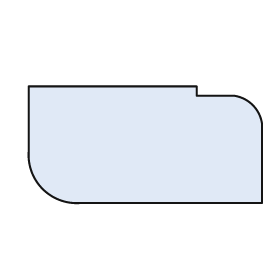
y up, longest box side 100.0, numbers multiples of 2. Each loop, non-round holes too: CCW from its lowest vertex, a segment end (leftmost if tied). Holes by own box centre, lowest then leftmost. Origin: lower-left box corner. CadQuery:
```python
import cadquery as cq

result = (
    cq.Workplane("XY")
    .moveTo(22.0, 0.0)
    .lineTo(100.0, 0.0)
    .lineTo(100.0, 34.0)
    .threePointArc((96.0, 42.0), (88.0, 46.0))
    .lineTo(72.0, 46.0)
    .lineTo(72.0, 50.0)
    .lineTo(0.0, 50.0)
    .lineTo(0.0, 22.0)
    .threePointArc((6.0, 6.0), (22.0, 0.0))
    .close()
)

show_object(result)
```